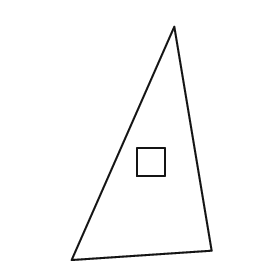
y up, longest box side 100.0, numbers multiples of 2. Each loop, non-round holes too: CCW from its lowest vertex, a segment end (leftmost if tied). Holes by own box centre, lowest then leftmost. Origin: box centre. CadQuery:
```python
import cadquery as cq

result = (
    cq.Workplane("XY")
    .moveTo(-30.0, -50.0)
    .lineTo(30.0, -46.0)
    .lineTo(14.0, 50.0)
    .close()
    .moveTo(-2.0, -14.0)
    .lineTo(10.0, -14.0)
    .lineTo(10.0, -2.0)
    .lineTo(-2.0, -2.0)
    .close()
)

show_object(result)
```